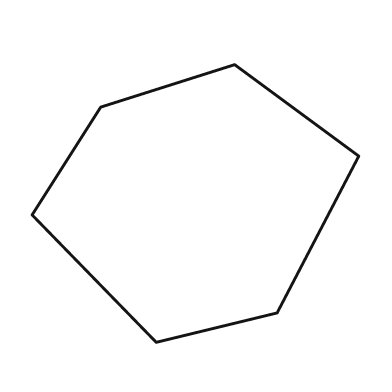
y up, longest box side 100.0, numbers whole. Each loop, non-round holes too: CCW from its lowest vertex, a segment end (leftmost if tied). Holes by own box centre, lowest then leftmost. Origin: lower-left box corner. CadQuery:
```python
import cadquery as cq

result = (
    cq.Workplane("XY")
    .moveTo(38.0, 0.0)
    .lineTo(75.0, 9.0)
    .lineTo(100.0, 57.0)
    .lineTo(62.0, 85.0)
    .lineTo(21.0, 72.0)
    .lineTo(0.0, 39.0)
    .close()
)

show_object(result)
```